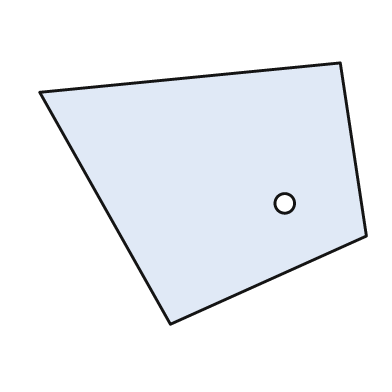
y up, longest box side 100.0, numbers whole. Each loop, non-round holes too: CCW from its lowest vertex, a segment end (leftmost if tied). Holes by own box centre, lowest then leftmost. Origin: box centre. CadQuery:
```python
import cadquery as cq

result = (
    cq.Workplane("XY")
    .moveTo(-10.0, -40.0)
    .lineTo(50.0, -13.0)
    .lineTo(42.0, 40.0)
    .lineTo(-50.0, 31.0)
    .close()
    .moveTo(25.0, -3.0)
    .circle(3.0)
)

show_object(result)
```